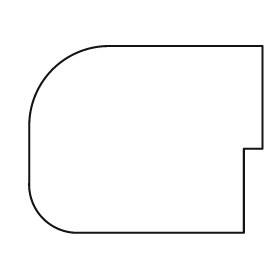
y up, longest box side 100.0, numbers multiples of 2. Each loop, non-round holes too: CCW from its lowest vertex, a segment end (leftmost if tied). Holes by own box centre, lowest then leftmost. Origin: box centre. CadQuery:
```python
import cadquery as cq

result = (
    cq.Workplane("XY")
    .moveTo(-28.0, -40.0)
    .lineTo(42.0, -40.0)
    .lineTo(42.0, -4.0)
    .lineTo(50.0, -4.0)
    .lineTo(50.0, 40.0)
    .lineTo(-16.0, 40.0)
    .threePointArc((-40.0, 30.0), (-50.0, 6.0))
    .lineTo(-50.0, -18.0)
    .threePointArc((-44.0, -34.0), (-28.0, -40.0))
    .close()
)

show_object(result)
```